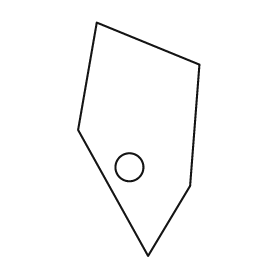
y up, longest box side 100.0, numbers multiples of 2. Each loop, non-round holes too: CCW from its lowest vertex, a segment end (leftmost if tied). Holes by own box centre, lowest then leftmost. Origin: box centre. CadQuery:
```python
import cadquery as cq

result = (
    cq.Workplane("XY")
    .moveTo(4.0, -50.0)
    .lineTo(22.0, -20.0)
    .lineTo(26.0, 32.0)
    .lineTo(-18.0, 50.0)
    .lineTo(-26.0, 4.0)
    .close()
    .moveTo(-4.0, -12.0)
    .circle(6.0)
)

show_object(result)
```